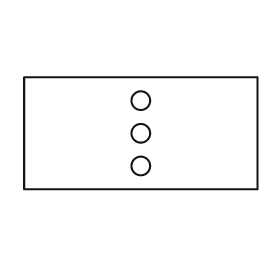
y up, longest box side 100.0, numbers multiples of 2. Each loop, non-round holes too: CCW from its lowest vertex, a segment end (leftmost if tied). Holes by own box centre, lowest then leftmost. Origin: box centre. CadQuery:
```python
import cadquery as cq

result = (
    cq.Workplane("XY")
    .moveTo(-50.0, -24.0)
    .lineTo(50.0, -24.0)
    .lineTo(50.0, 24.0)
    .lineTo(-50.0, 24.0)
    .close()
    .moveTo(0.0, -14.0)
    .circle(4.0)
    .moveTo(0.0, 0.0)
    .circle(4.0)
    .moveTo(0.0, 14.0)
    .circle(4.0)
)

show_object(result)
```